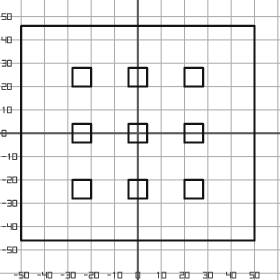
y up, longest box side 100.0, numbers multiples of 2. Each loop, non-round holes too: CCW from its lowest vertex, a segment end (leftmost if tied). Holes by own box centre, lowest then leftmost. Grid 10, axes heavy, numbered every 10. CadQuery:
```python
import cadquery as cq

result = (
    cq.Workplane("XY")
    .moveTo(-50.0, -46.0)
    .lineTo(50.0, -46.0)
    .lineTo(50.0, 46.0)
    .lineTo(-50.0, 46.0)
    .close()
    .moveTo(-28.0, -28.0)
    .lineTo(-20.0, -28.0)
    .lineTo(-20.0, -20.0)
    .lineTo(-28.0, -20.0)
    .close()
    .moveTo(-4.0, -28.0)
    .lineTo(4.0, -28.0)
    .lineTo(4.0, -20.0)
    .lineTo(-4.0, -20.0)
    .close()
    .moveTo(20.0, -28.0)
    .lineTo(28.0, -28.0)
    .lineTo(28.0, -20.0)
    .lineTo(20.0, -20.0)
    .close()
    .moveTo(-28.0, -4.0)
    .lineTo(-20.0, -4.0)
    .lineTo(-20.0, 4.0)
    .lineTo(-28.0, 4.0)
    .close()
    .moveTo(-4.0, -4.0)
    .lineTo(4.0, -4.0)
    .lineTo(4.0, 4.0)
    .lineTo(-4.0, 4.0)
    .close()
    .moveTo(20.0, -4.0)
    .lineTo(28.0, -4.0)
    .lineTo(28.0, 4.0)
    .lineTo(20.0, 4.0)
    .close()
    .moveTo(-28.0, 20.0)
    .lineTo(-20.0, 20.0)
    .lineTo(-20.0, 28.0)
    .lineTo(-28.0, 28.0)
    .close()
    .moveTo(-4.0, 20.0)
    .lineTo(4.0, 20.0)
    .lineTo(4.0, 28.0)
    .lineTo(-4.0, 28.0)
    .close()
    .moveTo(20.0, 20.0)
    .lineTo(28.0, 20.0)
    .lineTo(28.0, 28.0)
    .lineTo(20.0, 28.0)
    .close()
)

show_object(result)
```